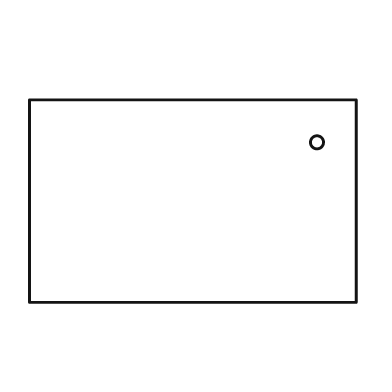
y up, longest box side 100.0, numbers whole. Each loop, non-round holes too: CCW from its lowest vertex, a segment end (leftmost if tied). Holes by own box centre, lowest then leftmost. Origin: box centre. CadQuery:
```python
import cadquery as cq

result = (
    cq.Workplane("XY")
    .moveTo(-50.0, -31.0)
    .lineTo(50.0, -31.0)
    .lineTo(50.0, 31.0)
    .lineTo(-50.0, 31.0)
    .close()
    .moveTo(38.0, 18.0)
    .circle(2.0)
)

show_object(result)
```